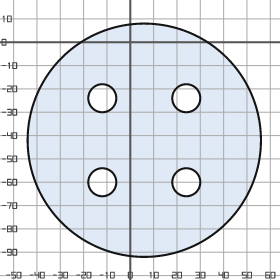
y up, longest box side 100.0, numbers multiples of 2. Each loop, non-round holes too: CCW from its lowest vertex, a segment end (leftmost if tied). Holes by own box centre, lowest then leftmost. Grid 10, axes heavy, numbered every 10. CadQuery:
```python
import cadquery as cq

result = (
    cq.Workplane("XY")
    .moveTo(6.0, -42.0)
    .circle(50.0)
    .moveTo(-12.0, -60.0)
    .circle(6.0)
    .moveTo(24.0, -60.0)
    .circle(6.0)
    .moveTo(-12.0, -24.0)
    .circle(6.0)
    .moveTo(24.0, -24.0)
    .circle(6.0)
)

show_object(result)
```